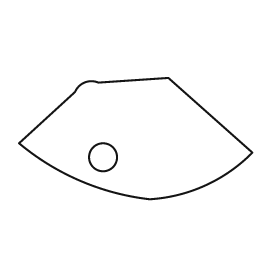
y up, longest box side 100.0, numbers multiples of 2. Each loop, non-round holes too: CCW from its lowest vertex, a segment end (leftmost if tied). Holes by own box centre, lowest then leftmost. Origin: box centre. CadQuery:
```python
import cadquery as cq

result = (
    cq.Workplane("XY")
    .moveTo(6.0, -26.0)
    .threePointArc((30.0, -20.0), (50.0, -6.0))
    .lineTo(14.0, 26.0)
    .lineTo(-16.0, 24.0)
    .threePointArc((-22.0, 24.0), (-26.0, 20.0))
    .lineTo(-50.0, -2.0)
    .threePointArc((-24.0, -18.0), (6.0, -26.0))
    .close()
    .moveTo(-14.0, -8.0)
    .circle(6.0)
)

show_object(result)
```